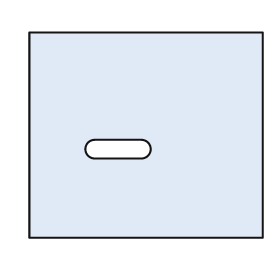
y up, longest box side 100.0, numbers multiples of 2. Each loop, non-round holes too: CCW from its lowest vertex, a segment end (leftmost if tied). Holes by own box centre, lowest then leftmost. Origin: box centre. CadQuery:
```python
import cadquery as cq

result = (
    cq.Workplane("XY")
    .moveTo(-50.0, -44.0)
    .lineTo(50.0, -44.0)
    .lineTo(50.0, 44.0)
    .lineTo(-50.0, 44.0)
    .close()
    .moveTo(-22.0, -10.0)
    .lineTo(-2.0, -10.0)
    .threePointArc((2.0, -6.0), (-2.0, -2.0))
    .lineTo(-22.0, -2.0)
    .threePointArc((-26.0, -6.0), (-22.0, -10.0))
    .close()
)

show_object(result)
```